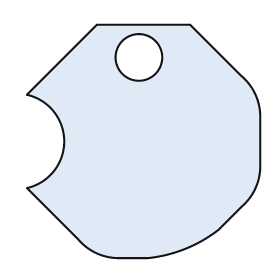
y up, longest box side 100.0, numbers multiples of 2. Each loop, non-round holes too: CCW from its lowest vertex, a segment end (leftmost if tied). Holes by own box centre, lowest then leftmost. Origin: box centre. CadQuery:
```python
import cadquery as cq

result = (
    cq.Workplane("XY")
    .moveTo(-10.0, -50.0)
    .lineTo(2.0, -50.0)
    .threePointArc((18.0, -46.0), (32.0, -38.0))
    .lineTo(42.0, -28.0)
    .threePointArc((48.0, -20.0), (50.0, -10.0))
    .lineTo(50.0, 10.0)
    .threePointArc((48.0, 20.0), (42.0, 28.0))
    .lineTo(20.0, 50.0)
    .lineTo(-20.0, 50.0)
    .lineTo(-50.0, 20.0)
    .threePointArc((-34.0, 0.0), (-50.0, -20.0))
    .lineTo(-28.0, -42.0)
    .threePointArc((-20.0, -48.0), (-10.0, -50.0))
    .close()
    .moveTo(-2.0, 36.0)
    .circle(10.0)
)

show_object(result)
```